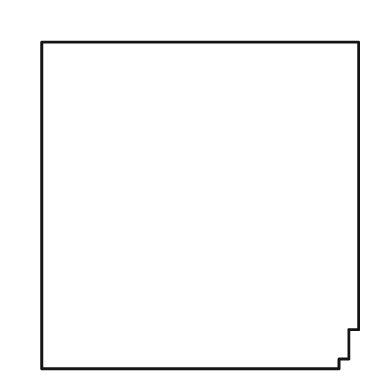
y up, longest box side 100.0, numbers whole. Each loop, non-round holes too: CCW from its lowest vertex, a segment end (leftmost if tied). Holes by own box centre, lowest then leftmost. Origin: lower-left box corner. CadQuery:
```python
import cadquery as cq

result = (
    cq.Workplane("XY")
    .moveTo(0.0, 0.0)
    .lineTo(91.0, 0.0)
    .lineTo(91.0, 3.0)
    .lineTo(94.0, 3.0)
    .lineTo(94.0, 12.0)
    .lineTo(97.0, 12.0)
    .lineTo(97.0, 100.0)
    .lineTo(0.0, 100.0)
    .close()
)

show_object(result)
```